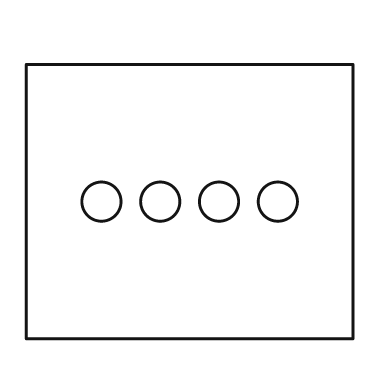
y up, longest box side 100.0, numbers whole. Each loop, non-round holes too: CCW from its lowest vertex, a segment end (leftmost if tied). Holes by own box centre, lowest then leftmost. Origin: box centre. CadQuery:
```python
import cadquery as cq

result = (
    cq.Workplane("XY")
    .moveTo(-50.0, -42.0)
    .lineTo(50.0, -42.0)
    .lineTo(50.0, 42.0)
    .lineTo(-50.0, 42.0)
    .close()
    .moveTo(-27.0, 0.0)
    .circle(6.0)
    .moveTo(-9.0, 0.0)
    .circle(6.0)
    .moveTo(9.0, 0.0)
    .circle(6.0)
    .moveTo(27.0, 0.0)
    .circle(6.0)
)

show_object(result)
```